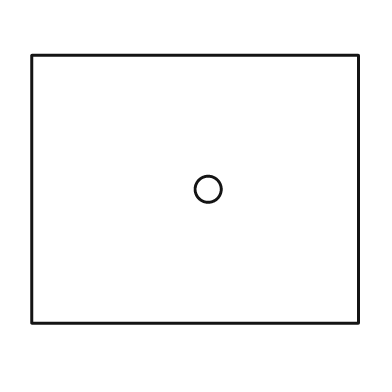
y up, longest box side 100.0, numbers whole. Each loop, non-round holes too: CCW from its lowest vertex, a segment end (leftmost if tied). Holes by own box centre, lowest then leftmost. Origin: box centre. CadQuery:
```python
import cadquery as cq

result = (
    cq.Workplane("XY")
    .moveTo(-50.0, -41.0)
    .lineTo(50.0, -41.0)
    .lineTo(50.0, 41.0)
    .lineTo(-50.0, 41.0)
    .close()
    .moveTo(4.0, 0.0)
    .circle(4.0)
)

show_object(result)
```